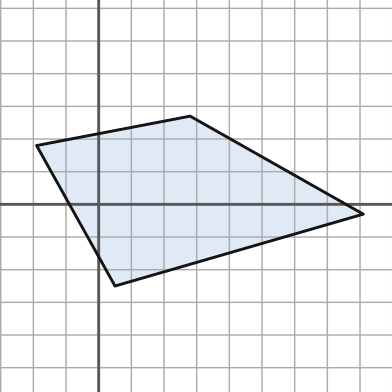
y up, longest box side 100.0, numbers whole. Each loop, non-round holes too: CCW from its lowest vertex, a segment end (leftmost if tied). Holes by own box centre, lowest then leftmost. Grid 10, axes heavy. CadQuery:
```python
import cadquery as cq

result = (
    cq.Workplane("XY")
    .moveTo(5.0, -25.0)
    .lineTo(81.0, -3.0)
    .lineTo(28.0, 27.0)
    .lineTo(-19.0, 18.0)
    .close()
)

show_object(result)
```